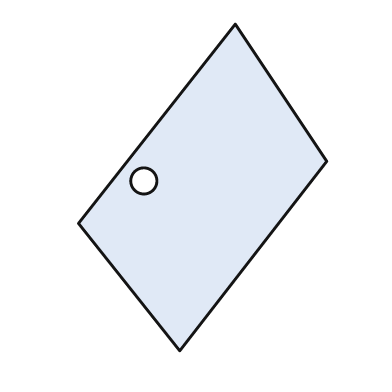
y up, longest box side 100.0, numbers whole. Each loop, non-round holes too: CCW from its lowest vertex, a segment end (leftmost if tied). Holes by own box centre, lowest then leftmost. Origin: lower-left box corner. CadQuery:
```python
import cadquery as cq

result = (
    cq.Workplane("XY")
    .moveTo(31.0, 0.0)
    .lineTo(76.0, 58.0)
    .lineTo(48.0, 100.0)
    .lineTo(0.0, 39.0)
    .close()
    .moveTo(20.0, 52.0)
    .circle(4.0)
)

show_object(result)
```